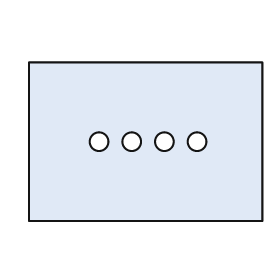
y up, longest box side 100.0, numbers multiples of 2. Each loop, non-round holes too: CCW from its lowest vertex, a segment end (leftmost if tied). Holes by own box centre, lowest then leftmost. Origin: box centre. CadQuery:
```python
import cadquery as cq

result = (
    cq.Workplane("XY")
    .moveTo(-50.0, -34.0)
    .lineTo(50.0, -34.0)
    .lineTo(50.0, 34.0)
    .lineTo(-50.0, 34.0)
    .close()
    .moveTo(-20.0, 0.0)
    .circle(4.0)
    .moveTo(-6.0, 0.0)
    .circle(4.0)
    .moveTo(8.0, 0.0)
    .circle(4.0)
    .moveTo(22.0, 0.0)
    .circle(4.0)
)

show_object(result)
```